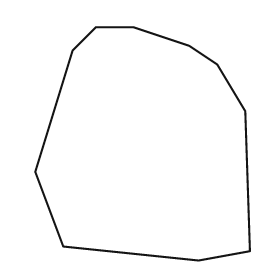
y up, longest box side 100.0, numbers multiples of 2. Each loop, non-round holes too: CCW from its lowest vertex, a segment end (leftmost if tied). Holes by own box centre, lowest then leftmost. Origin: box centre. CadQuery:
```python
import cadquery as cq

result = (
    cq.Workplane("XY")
    .moveTo(24.0, -50.0)
    .lineTo(46.0, -46.0)
    .lineTo(44.0, 14.0)
    .lineTo(32.0, 34.0)
    .lineTo(20.0, 42.0)
    .lineTo(-4.0, 50.0)
    .lineTo(-20.0, 50.0)
    .lineTo(-30.0, 40.0)
    .lineTo(-46.0, -12.0)
    .lineTo(-34.0, -44.0)
    .close()
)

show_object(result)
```